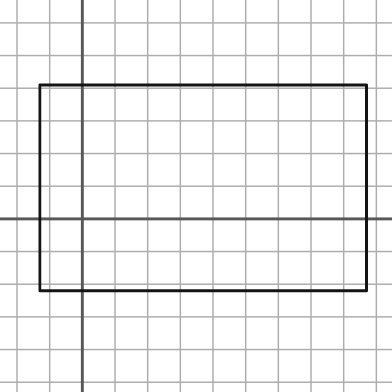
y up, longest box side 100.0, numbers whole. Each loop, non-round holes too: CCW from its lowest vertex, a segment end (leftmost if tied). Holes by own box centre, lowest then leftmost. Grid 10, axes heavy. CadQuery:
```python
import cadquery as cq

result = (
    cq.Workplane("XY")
    .moveTo(-13.0, -22.0)
    .lineTo(87.0, -22.0)
    .lineTo(87.0, 41.0)
    .lineTo(-13.0, 41.0)
    .close()
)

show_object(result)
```